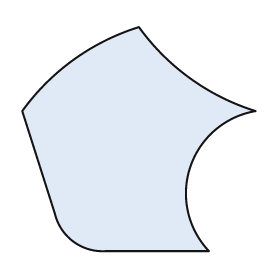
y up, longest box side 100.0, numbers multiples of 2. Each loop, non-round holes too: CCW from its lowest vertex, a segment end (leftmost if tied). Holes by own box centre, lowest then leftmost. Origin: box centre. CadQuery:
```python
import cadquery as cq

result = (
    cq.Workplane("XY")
    .moveTo(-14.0, -48.0)
    .lineTo(30.0, -48.0)
    .threePointArc((22.0, -12.0), (50.0, 12.0))
    .threePointArc((22.0, 26.0), (0.0, 48.0))
    .threePointArc((-28.0, 34.0), (-50.0, 12.0))
    .lineTo(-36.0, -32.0)
    .threePointArc((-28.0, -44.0), (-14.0, -48.0))
    .close()
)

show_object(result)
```